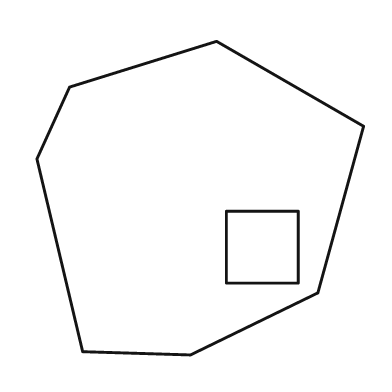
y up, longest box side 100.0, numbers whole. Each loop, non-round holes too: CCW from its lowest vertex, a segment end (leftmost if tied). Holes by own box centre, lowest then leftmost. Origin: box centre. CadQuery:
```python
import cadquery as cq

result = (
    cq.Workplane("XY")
    .moveTo(-3.0, -48.0)
    .lineTo(36.0, -29.0)
    .lineTo(50.0, 22.0)
    .lineTo(5.0, 48.0)
    .lineTo(-40.0, 34.0)
    .lineTo(-50.0, 12.0)
    .lineTo(-36.0, -47.0)
    .close()
    .moveTo(8.0, -26.0)
    .lineTo(30.0, -26.0)
    .lineTo(30.0, -4.0)
    .lineTo(8.0, -4.0)
    .close()
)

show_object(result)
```